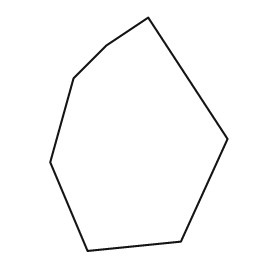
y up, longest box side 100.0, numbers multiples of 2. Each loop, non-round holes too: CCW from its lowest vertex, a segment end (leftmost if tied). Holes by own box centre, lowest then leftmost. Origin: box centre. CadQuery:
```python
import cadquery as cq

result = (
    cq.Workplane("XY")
    .moveTo(-22.0, -50.0)
    .lineTo(18.0, -46.0)
    .lineTo(38.0, -2.0)
    .lineTo(4.0, 50.0)
    .lineTo(-14.0, 38.0)
    .lineTo(-28.0, 24.0)
    .lineTo(-38.0, -12.0)
    .close()
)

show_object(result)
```